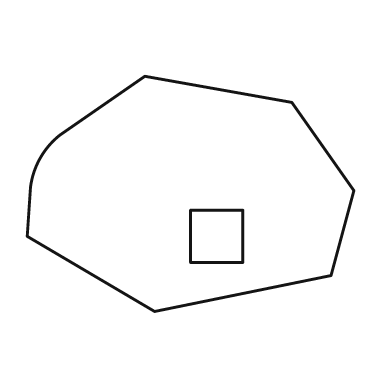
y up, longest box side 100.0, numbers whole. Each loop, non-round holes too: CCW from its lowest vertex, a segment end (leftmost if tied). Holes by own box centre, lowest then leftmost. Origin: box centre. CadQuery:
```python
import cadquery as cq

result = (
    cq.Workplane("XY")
    .moveTo(-11.0, -36.0)
    .lineTo(43.0, -25.0)
    .lineTo(50.0, 1.0)
    .lineTo(31.0, 28.0)
    .lineTo(-14.0, 36.0)
    .lineTo(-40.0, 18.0)
    .threePointArc((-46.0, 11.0), (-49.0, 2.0))
    .lineTo(-50.0, -13.0)
    .close()
    .moveTo(0.0, -21.0)
    .lineTo(16.0, -21.0)
    .lineTo(16.0, -5.0)
    .lineTo(0.0, -5.0)
    .close()
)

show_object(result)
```